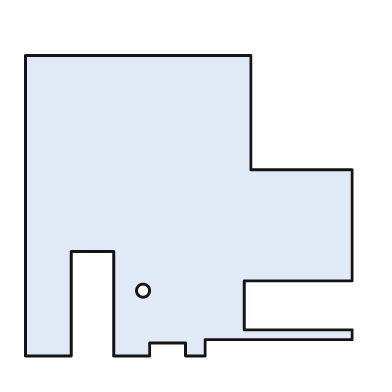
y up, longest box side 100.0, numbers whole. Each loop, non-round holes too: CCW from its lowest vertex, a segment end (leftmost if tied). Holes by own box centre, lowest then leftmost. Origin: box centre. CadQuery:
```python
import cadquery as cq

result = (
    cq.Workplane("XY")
    .moveTo(-50.0, -46.0)
    .lineTo(-36.0, -46.0)
    .lineTo(-36.0, -14.0)
    .lineTo(-23.0, -14.0)
    .lineTo(-23.0, -46.0)
    .lineTo(-12.0, -46.0)
    .lineTo(-12.0, -42.0)
    .lineTo(-1.0, -42.0)
    .lineTo(-1.0, -46.0)
    .lineTo(5.0, -46.0)
    .lineTo(5.0, -41.0)
    .lineTo(50.0, -41.0)
    .lineTo(50.0, -38.0)
    .lineTo(17.0, -38.0)
    .lineTo(17.0, -23.0)
    .lineTo(50.0, -23.0)
    .lineTo(50.0, 11.0)
    .lineTo(19.0, 11.0)
    .lineTo(19.0, 46.0)
    .lineTo(-50.0, 46.0)
    .close()
    .moveTo(-14.0, -26.0)
    .circle(2.0)
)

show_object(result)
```